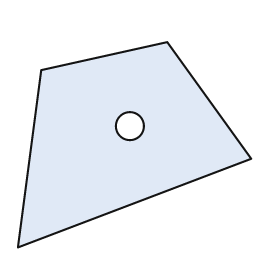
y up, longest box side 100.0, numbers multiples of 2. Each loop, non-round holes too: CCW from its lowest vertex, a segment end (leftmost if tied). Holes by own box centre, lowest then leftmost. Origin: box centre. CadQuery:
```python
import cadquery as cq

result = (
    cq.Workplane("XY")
    .moveTo(-50.0, -44.0)
    .lineTo(50.0, -6.0)
    .lineTo(14.0, 44.0)
    .lineTo(-40.0, 32.0)
    .close()
    .moveTo(-2.0, 8.0)
    .circle(6.0)
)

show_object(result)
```